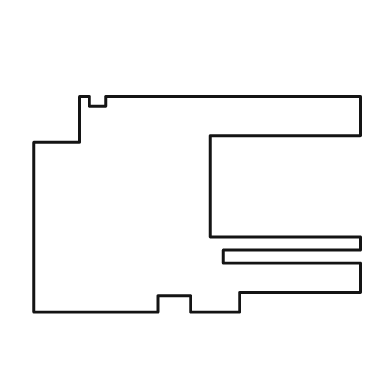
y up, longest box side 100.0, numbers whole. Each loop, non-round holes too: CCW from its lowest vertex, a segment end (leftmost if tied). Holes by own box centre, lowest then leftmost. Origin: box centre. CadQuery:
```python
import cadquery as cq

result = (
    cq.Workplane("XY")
    .moveTo(-50.0, -33.0)
    .lineTo(-12.0, -33.0)
    .lineTo(-12.0, -28.0)
    .lineTo(-2.0, -28.0)
    .lineTo(-2.0, -33.0)
    .lineTo(13.0, -33.0)
    .lineTo(13.0, -27.0)
    .lineTo(50.0, -27.0)
    .lineTo(50.0, -18.0)
    .lineTo(8.0, -18.0)
    .lineTo(8.0, -14.0)
    .lineTo(50.0, -14.0)
    .lineTo(50.0, -10.0)
    .lineTo(4.0, -10.0)
    .lineTo(4.0, 21.0)
    .lineTo(50.0, 21.0)
    .lineTo(50.0, 33.0)
    .lineTo(-28.0, 33.0)
    .lineTo(-28.0, 30.0)
    .lineTo(-33.0, 30.0)
    .lineTo(-33.0, 33.0)
    .lineTo(-36.0, 33.0)
    .lineTo(-36.0, 19.0)
    .lineTo(-50.0, 19.0)
    .close()
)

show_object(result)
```